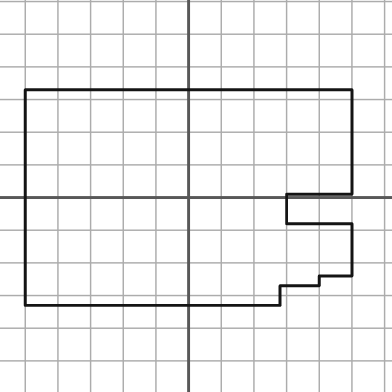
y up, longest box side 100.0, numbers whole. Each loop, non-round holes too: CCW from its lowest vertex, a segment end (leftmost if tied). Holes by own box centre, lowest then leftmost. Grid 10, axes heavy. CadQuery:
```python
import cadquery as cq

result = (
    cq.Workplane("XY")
    .moveTo(-50.0, -33.0)
    .lineTo(28.0, -33.0)
    .lineTo(28.0, -27.0)
    .lineTo(40.0, -27.0)
    .lineTo(40.0, -24.0)
    .lineTo(50.0, -24.0)
    .lineTo(50.0, -8.0)
    .lineTo(30.0, -8.0)
    .lineTo(30.0, 1.0)
    .lineTo(50.0, 1.0)
    .lineTo(50.0, 33.0)
    .lineTo(-50.0, 33.0)
    .close()
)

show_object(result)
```